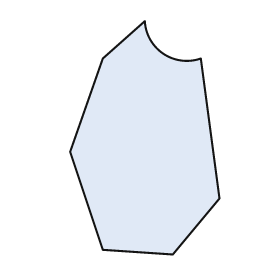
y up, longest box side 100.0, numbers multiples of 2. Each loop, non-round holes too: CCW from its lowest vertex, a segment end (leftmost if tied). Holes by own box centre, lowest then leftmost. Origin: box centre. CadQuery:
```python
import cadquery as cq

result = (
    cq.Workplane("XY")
    .moveTo(12.0, -50.0)
    .lineTo(32.0, -26.0)
    .lineTo(24.0, 34.0)
    .threePointArc((8.0, 36.0), (0.0, 50.0))
    .lineTo(-18.0, 34.0)
    .lineTo(-32.0, -6.0)
    .lineTo(-18.0, -48.0)
    .close()
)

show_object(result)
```